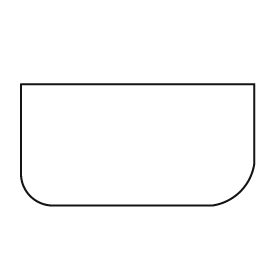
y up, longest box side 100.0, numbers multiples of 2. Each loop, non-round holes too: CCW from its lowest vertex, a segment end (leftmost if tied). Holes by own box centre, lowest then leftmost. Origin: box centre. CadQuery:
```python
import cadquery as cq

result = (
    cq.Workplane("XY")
    .moveTo(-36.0, -26.0)
    .lineTo(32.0, -26.0)
    .threePointArc((44.0, -20.0), (50.0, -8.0))
    .lineTo(50.0, 26.0)
    .lineTo(-50.0, 26.0)
    .lineTo(-50.0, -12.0)
    .threePointArc((-46.0, -22.0), (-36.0, -26.0))
    .close()
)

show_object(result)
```